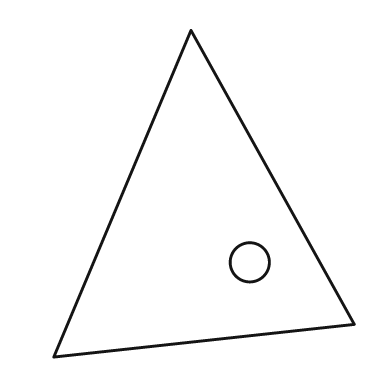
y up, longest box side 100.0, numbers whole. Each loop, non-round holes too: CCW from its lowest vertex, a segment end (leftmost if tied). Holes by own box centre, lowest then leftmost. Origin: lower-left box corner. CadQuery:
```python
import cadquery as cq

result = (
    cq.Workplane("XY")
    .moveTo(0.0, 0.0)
    .lineTo(92.0, 10.0)
    .lineTo(42.0, 100.0)
    .close()
    .moveTo(60.0, 29.0)
    .circle(6.0)
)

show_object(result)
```